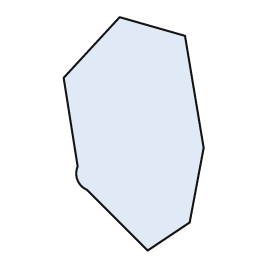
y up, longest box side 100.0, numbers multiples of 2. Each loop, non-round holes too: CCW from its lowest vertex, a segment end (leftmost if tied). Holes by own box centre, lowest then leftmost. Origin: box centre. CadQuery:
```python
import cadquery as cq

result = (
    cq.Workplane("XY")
    .moveTo(6.0, -50.0)
    .lineTo(24.0, -38.0)
    .lineTo(30.0, -6.0)
    .lineTo(22.0, 42.0)
    .lineTo(-6.0, 50.0)
    .lineTo(-30.0, 24.0)
    .lineTo(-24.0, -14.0)
    .threePointArc((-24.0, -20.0), (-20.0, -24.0))
    .close()
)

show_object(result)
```